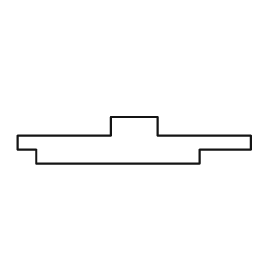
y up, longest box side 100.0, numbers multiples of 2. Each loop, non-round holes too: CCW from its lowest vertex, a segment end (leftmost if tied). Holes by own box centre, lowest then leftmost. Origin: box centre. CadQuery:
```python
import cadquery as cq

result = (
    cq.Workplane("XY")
    .moveTo(-42.0, -10.0)
    .lineTo(28.0, -10.0)
    .lineTo(28.0, -4.0)
    .lineTo(50.0, -4.0)
    .lineTo(50.0, 2.0)
    .lineTo(10.0, 2.0)
    .lineTo(10.0, 10.0)
    .lineTo(-10.0, 10.0)
    .lineTo(-10.0, 2.0)
    .lineTo(-50.0, 2.0)
    .lineTo(-50.0, -4.0)
    .lineTo(-42.0, -4.0)
    .close()
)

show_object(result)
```